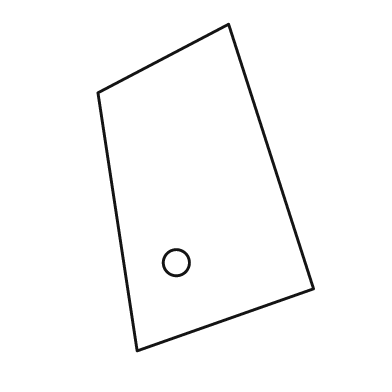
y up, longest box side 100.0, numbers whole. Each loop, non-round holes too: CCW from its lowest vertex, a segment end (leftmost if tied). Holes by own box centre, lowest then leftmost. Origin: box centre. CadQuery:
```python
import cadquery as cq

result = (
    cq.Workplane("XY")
    .moveTo(-21.0, -50.0)
    .lineTo(33.0, -31.0)
    .lineTo(7.0, 50.0)
    .lineTo(-33.0, 29.0)
    .close()
    .moveTo(-9.0, -23.0)
    .circle(4.0)
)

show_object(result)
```